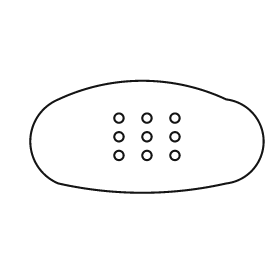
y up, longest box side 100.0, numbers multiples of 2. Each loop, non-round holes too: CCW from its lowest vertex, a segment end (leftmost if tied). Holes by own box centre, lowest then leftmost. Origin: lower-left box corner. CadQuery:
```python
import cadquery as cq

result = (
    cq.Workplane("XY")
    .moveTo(12.0, 4.0)
    .threePointArc((48.0, 0.0), (84.0, 4.0))
    .threePointArc((100.0, 22.0), (84.0, 40.0))
    .threePointArc((48.0, 48.0), (12.0, 40.0))
    .threePointArc((0.0, 22.0), (12.0, 4.0))
    .close()
    .moveTo(38.0, 16.0)
    .circle(2.0)
    .moveTo(50.0, 16.0)
    .circle(2.0)
    .moveTo(62.0, 16.0)
    .circle(2.0)
    .moveTo(38.0, 24.0)
    .circle(2.0)
    .moveTo(50.0, 24.0)
    .circle(2.0)
    .moveTo(62.0, 24.0)
    .circle(2.0)
    .moveTo(38.0, 32.0)
    .circle(2.0)
    .moveTo(50.0, 32.0)
    .circle(2.0)
    .moveTo(62.0, 32.0)
    .circle(2.0)
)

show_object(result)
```